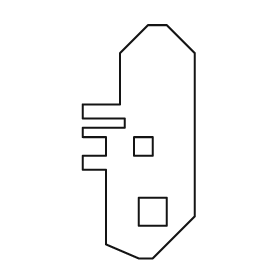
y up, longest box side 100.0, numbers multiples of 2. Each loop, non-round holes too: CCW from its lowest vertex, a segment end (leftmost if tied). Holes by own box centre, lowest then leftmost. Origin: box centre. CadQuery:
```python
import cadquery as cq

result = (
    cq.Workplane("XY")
    .moveTo(0.0, -50.0)
    .lineTo(6.0, -50.0)
    .lineTo(24.0, -32.0)
    .lineTo(24.0, 38.0)
    .lineTo(12.0, 50.0)
    .lineTo(4.0, 50.0)
    .lineTo(-8.0, 38.0)
    .lineTo(-8.0, 16.0)
    .lineTo(-24.0, 16.0)
    .lineTo(-24.0, 10.0)
    .lineTo(-6.0, 10.0)
    .lineTo(-6.0, 6.0)
    .lineTo(-24.0, 6.0)
    .lineTo(-24.0, 2.0)
    .lineTo(-14.0, 2.0)
    .lineTo(-14.0, -6.0)
    .lineTo(-24.0, -6.0)
    .lineTo(-24.0, -12.0)
    .lineTo(-14.0, -12.0)
    .lineTo(-14.0, -44.0)
    .close()
    .moveTo(0.0, -36.0)
    .lineTo(12.0, -36.0)
    .lineTo(12.0, -24.0)
    .lineTo(0.0, -24.0)
    .close()
    .moveTo(-2.0, -6.0)
    .lineTo(6.0, -6.0)
    .lineTo(6.0, 2.0)
    .lineTo(-2.0, 2.0)
    .close()
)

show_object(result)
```